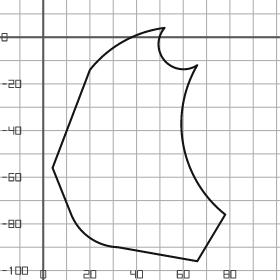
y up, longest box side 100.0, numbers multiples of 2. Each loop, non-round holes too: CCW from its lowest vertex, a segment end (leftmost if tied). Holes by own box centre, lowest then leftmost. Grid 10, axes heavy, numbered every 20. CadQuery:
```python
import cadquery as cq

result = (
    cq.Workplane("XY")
    .moveTo(66.0, -96.0)
    .lineTo(78.0, -76.0)
    .threePointArc((60.0, -46.0), (66.0, -12.0))
    .threePointArc((52.0, -10.0), (52.0, 4.0))
    .threePointArc((34.0, -2.0), (20.0, -14.0))
    .lineTo(4.0, -56.0)
    .lineTo(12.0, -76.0)
    .threePointArc((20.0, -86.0), (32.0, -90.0))
    .close()
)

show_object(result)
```